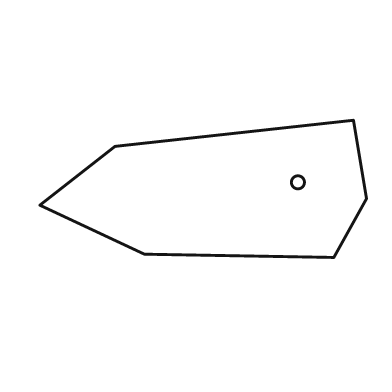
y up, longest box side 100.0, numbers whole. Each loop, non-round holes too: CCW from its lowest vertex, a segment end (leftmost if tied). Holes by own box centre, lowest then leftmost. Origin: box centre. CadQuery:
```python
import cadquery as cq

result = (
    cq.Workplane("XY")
    .moveTo(40.0, -21.0)
    .lineTo(50.0, -3.0)
    .lineTo(46.0, 21.0)
    .lineTo(-27.0, 13.0)
    .lineTo(-50.0, -5.0)
    .lineTo(-18.0, -20.0)
    .close()
    .moveTo(29.0, 2.0)
    .circle(2.0)
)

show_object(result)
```